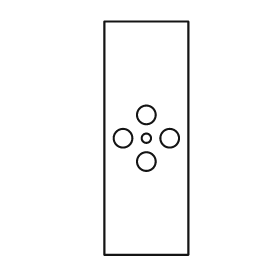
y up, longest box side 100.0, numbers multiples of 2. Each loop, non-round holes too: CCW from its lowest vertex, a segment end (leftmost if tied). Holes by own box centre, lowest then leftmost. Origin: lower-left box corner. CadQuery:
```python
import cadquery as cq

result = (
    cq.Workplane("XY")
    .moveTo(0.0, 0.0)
    .lineTo(36.0, 0.0)
    .lineTo(36.0, 100.0)
    .lineTo(0.0, 100.0)
    .close()
    .moveTo(18.0, 40.0)
    .circle(4.0)
    .moveTo(8.0, 50.0)
    .circle(4.0)
    .moveTo(18.0, 50.0)
    .circle(2.0)
    .moveTo(28.0, 50.0)
    .circle(4.0)
    .moveTo(18.0, 60.0)
    .circle(4.0)
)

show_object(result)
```